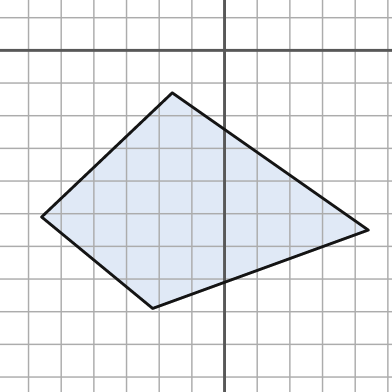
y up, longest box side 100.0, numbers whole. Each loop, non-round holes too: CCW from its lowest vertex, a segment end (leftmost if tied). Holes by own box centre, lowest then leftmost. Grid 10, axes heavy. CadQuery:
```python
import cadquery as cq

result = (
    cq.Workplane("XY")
    .moveTo(-22.0, -79.0)
    .lineTo(44.0, -55.0)
    .lineTo(-16.0, -13.0)
    .lineTo(-56.0, -51.0)
    .close()
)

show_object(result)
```